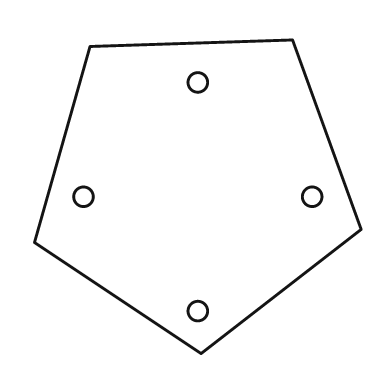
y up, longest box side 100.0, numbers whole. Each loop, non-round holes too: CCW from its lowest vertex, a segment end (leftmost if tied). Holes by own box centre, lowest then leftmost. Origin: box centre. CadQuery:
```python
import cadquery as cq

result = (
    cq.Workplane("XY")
    .moveTo(1.0, -48.0)
    .lineTo(50.0, -10.0)
    .lineTo(29.0, 48.0)
    .lineTo(-33.0, 46.0)
    .lineTo(-50.0, -14.0)
    .close()
    .moveTo(0.0, -35.0)
    .circle(3.0)
    .moveTo(-35.0, 0.0)
    .circle(3.0)
    .moveTo(35.0, 0.0)
    .circle(3.0)
    .moveTo(0.0, 35.0)
    .circle(3.0)
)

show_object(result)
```